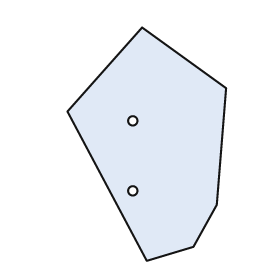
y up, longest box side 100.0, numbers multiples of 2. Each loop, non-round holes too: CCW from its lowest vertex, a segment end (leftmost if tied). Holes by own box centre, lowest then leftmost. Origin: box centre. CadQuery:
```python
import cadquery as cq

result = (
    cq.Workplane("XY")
    .moveTo(0.0, -50.0)
    .lineTo(20.0, -44.0)
    .lineTo(30.0, -26.0)
    .lineTo(34.0, 24.0)
    .lineTo(-2.0, 50.0)
    .lineTo(-34.0, 14.0)
    .close()
    .moveTo(-6.0, -20.0)
    .circle(2.0)
    .moveTo(-6.0, 10.0)
    .circle(2.0)
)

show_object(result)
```